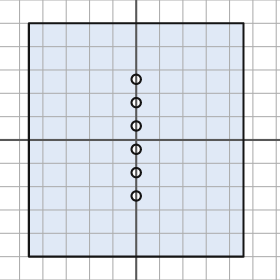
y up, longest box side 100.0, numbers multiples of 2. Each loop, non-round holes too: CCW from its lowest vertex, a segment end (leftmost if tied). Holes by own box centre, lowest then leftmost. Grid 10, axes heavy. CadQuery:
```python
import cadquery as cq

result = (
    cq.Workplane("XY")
    .moveTo(-46.0, -50.0)
    .lineTo(46.0, -50.0)
    .lineTo(46.0, 50.0)
    .lineTo(-46.0, 50.0)
    .close()
    .moveTo(0.0, -24.0)
    .circle(2.0)
    .moveTo(0.0, -14.0)
    .circle(2.0)
    .moveTo(0.0, -4.0)
    .circle(2.0)
    .moveTo(0.0, 6.0)
    .circle(2.0)
    .moveTo(0.0, 16.0)
    .circle(2.0)
    .moveTo(0.0, 26.0)
    .circle(2.0)
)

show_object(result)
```